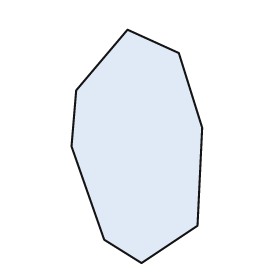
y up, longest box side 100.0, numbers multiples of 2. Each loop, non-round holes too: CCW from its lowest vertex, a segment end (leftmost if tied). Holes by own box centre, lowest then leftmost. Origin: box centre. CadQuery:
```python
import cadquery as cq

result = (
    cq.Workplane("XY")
    .moveTo(2.0, -50.0)
    .lineTo(26.0, -34.0)
    .lineTo(28.0, 8.0)
    .lineTo(18.0, 40.0)
    .lineTo(-4.0, 50.0)
    .lineTo(-26.0, 24.0)
    .lineTo(-28.0, 0.0)
    .lineTo(-14.0, -40.0)
    .close()
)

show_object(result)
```